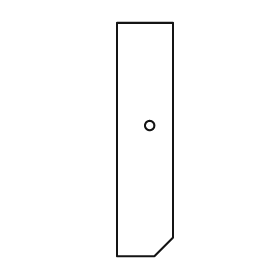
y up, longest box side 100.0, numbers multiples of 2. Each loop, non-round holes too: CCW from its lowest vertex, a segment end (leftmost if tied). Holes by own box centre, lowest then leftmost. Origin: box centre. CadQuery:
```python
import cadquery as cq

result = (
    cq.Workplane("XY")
    .moveTo(-12.0, -50.0)
    .lineTo(4.0, -50.0)
    .lineTo(12.0, -42.0)
    .lineTo(12.0, 50.0)
    .lineTo(-12.0, 50.0)
    .close()
    .moveTo(2.0, 6.0)
    .circle(2.0)
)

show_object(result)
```